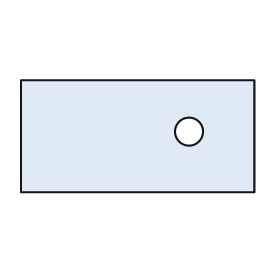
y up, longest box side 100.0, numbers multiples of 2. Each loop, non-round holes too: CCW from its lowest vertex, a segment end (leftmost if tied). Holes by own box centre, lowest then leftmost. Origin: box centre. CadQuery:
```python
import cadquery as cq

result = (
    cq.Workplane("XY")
    .moveTo(-50.0, -24.0)
    .lineTo(50.0, -24.0)
    .lineTo(50.0, 24.0)
    .lineTo(-50.0, 24.0)
    .close()
    .moveTo(22.0, 2.0)
    .circle(6.0)
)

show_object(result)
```